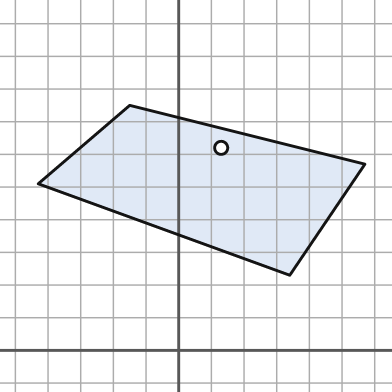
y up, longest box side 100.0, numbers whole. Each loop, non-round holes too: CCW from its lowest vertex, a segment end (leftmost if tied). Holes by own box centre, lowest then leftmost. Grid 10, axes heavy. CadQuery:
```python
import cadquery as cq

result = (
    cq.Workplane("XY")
    .moveTo(34.0, 23.0)
    .lineTo(57.0, 57.0)
    .lineTo(-15.0, 75.0)
    .lineTo(-43.0, 51.0)
    .close()
    .moveTo(13.0, 62.0)
    .circle(2.0)
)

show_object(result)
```